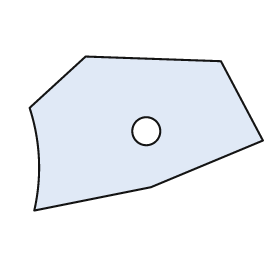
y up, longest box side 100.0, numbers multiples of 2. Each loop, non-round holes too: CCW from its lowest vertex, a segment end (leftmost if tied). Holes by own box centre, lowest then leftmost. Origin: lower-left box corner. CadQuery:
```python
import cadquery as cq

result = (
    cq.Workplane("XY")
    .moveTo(2.0, 0.0)
    .lineTo(52.0, 10.0)
    .lineTo(100.0, 30.0)
    .lineTo(82.0, 64.0)
    .lineTo(24.0, 66.0)
    .lineTo(0.0, 44.0)
    .threePointArc((4.0, 22.0), (2.0, 0.0))
    .close()
    .moveTo(50.0, 34.0)
    .circle(6.0)
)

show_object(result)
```